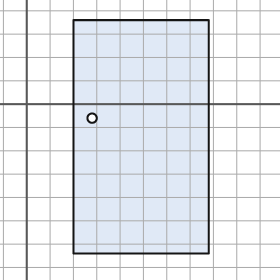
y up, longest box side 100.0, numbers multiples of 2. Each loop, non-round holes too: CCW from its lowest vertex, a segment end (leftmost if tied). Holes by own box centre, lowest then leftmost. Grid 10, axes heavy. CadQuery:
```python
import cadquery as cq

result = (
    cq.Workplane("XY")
    .moveTo(20.0, -64.0)
    .lineTo(78.0, -64.0)
    .lineTo(78.0, 36.0)
    .lineTo(20.0, 36.0)
    .close()
    .moveTo(28.0, -6.0)
    .circle(2.0)
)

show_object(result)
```